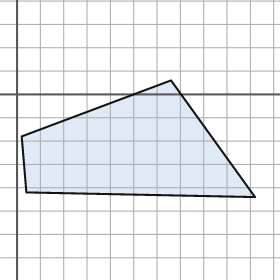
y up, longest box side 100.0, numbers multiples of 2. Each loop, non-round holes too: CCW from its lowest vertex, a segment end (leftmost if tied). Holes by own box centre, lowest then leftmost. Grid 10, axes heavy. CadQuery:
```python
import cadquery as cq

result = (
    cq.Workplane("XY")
    .moveTo(102.0, -44.0)
    .lineTo(66.0, 6.0)
    .lineTo(2.0, -18.0)
    .lineTo(4.0, -42.0)
    .close()
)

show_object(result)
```